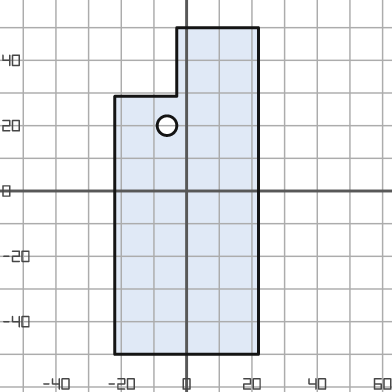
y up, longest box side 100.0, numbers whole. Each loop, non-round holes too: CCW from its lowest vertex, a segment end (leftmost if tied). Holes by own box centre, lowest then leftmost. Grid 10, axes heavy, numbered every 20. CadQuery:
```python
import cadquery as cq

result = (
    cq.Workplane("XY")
    .moveTo(-22.0, -50.0)
    .lineTo(22.0, -50.0)
    .lineTo(22.0, 50.0)
    .lineTo(-3.0, 50.0)
    .lineTo(-3.0, 29.0)
    .lineTo(-22.0, 29.0)
    .close()
    .moveTo(-6.0, 20.0)
    .circle(3.0)
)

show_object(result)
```